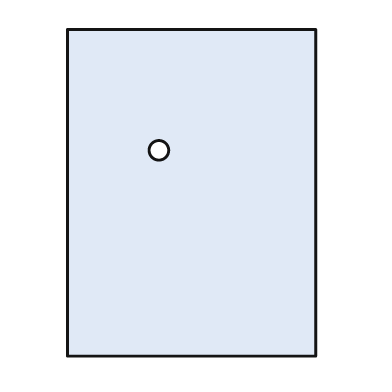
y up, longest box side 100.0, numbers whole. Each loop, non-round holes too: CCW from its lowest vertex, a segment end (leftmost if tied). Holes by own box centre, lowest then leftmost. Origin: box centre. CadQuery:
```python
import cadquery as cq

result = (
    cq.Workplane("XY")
    .moveTo(-38.0, -50.0)
    .lineTo(38.0, -50.0)
    .lineTo(38.0, 50.0)
    .lineTo(-38.0, 50.0)
    .close()
    .moveTo(-10.0, 13.0)
    .circle(3.0)
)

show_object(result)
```